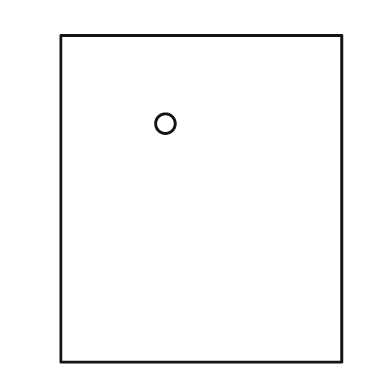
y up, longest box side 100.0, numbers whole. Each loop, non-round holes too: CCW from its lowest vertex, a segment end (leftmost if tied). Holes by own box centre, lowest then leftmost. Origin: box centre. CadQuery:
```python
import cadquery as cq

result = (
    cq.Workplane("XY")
    .moveTo(-43.0, -50.0)
    .lineTo(43.0, -50.0)
    .lineTo(43.0, 50.0)
    .lineTo(-43.0, 50.0)
    .close()
    .moveTo(-11.0, 23.0)
    .circle(3.0)
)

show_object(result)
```